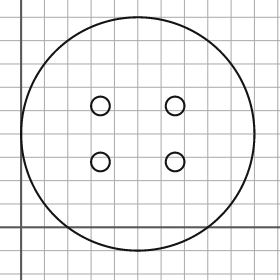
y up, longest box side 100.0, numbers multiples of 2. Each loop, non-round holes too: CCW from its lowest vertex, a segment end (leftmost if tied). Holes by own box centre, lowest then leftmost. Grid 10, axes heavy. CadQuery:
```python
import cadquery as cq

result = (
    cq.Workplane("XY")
    .moveTo(50.0, 40.0)
    .circle(50.0)
    .moveTo(34.0, 28.0)
    .circle(4.0)
    .moveTo(66.0, 28.0)
    .circle(4.0)
    .moveTo(34.0, 52.0)
    .circle(4.0)
    .moveTo(66.0, 52.0)
    .circle(4.0)
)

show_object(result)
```